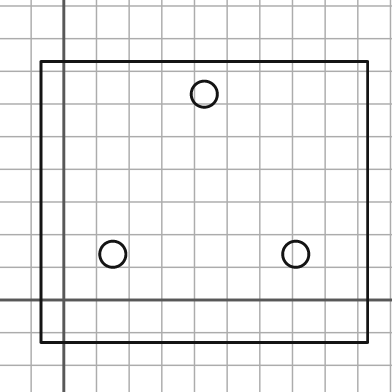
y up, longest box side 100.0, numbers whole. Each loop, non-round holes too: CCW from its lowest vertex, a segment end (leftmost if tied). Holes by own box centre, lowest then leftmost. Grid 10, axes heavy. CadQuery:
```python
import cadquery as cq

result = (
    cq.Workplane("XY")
    .moveTo(-7.0, -13.0)
    .lineTo(93.0, -13.0)
    .lineTo(93.0, 73.0)
    .lineTo(-7.0, 73.0)
    .close()
    .moveTo(15.0, 14.0)
    .circle(4.0)
    .moveTo(71.0, 14.0)
    .circle(4.0)
    .moveTo(43.0, 63.0)
    .circle(4.0)
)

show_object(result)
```